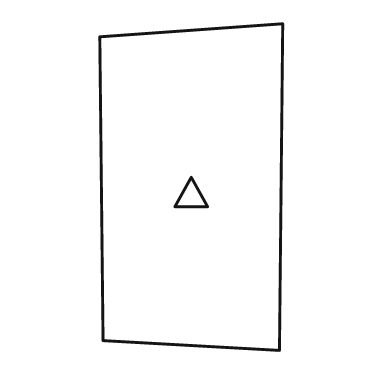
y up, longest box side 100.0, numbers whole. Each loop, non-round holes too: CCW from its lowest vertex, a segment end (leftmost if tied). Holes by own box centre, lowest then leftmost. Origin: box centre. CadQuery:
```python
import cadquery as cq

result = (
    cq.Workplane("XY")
    .moveTo(27.0, -50.0)
    .lineTo(28.0, 50.0)
    .lineTo(-28.0, 46.0)
    .lineTo(-27.0, -47.0)
    .close()
    .moveTo(-5.0, -6.0)
    .lineTo(5.0, -6.0)
    .lineTo(0.0, 3.0)
    .close()
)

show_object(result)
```